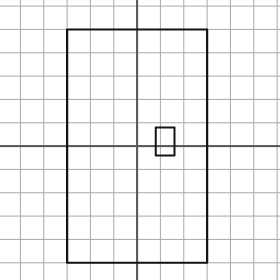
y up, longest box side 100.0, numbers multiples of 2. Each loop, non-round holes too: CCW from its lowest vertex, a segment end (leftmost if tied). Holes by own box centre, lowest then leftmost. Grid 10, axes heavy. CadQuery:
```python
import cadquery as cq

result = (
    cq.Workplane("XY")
    .moveTo(-30.0, -50.0)
    .lineTo(30.0, -50.0)
    .lineTo(30.0, 50.0)
    .lineTo(-30.0, 50.0)
    .close()
    .moveTo(8.0, -4.0)
    .lineTo(16.0, -4.0)
    .lineTo(16.0, 8.0)
    .lineTo(8.0, 8.0)
    .close()
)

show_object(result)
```